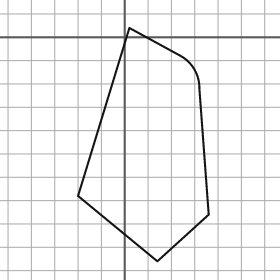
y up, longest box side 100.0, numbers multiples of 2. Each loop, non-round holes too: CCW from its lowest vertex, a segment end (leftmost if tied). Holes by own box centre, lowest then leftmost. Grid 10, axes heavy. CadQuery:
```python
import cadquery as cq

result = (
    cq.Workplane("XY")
    .moveTo(14.0, -96.0)
    .lineTo(36.0, -76.0)
    .lineTo(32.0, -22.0)
    .threePointArc((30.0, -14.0), (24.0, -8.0))
    .lineTo(2.0, 4.0)
    .lineTo(-20.0, -68.0)
    .close()
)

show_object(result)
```